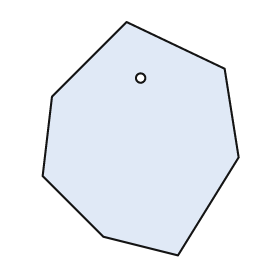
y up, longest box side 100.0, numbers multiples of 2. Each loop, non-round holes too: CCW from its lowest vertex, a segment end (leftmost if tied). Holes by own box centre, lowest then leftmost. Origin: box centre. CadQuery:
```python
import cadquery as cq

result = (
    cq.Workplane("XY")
    .moveTo(16.0, -50.0)
    .lineTo(42.0, -8.0)
    .lineTo(36.0, 30.0)
    .lineTo(-6.0, 50.0)
    .lineTo(-38.0, 18.0)
    .lineTo(-42.0, -16.0)
    .lineTo(-16.0, -42.0)
    .close()
    .moveTo(0.0, 26.0)
    .circle(2.0)
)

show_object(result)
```